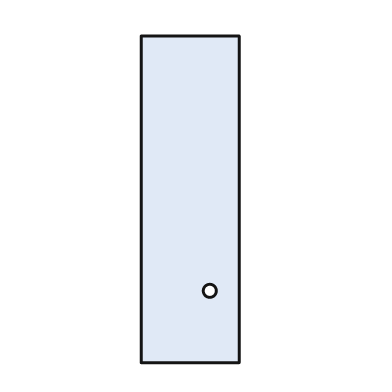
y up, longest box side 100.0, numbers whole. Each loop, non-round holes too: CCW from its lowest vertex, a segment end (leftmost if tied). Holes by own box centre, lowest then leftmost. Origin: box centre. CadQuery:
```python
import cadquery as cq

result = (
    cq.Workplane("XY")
    .moveTo(-15.0, -50.0)
    .lineTo(15.0, -50.0)
    .lineTo(15.0, 50.0)
    .lineTo(-15.0, 50.0)
    .close()
    .moveTo(6.0, -28.0)
    .circle(2.0)
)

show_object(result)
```